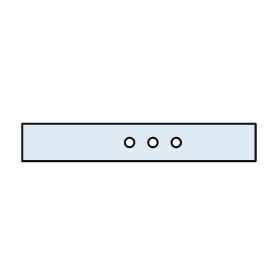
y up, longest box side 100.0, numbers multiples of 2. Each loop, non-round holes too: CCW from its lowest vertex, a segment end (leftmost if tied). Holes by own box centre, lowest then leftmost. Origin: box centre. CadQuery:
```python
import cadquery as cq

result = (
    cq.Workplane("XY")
    .moveTo(-50.0, -8.0)
    .lineTo(50.0, -8.0)
    .lineTo(50.0, 8.0)
    .lineTo(-50.0, 8.0)
    .close()
    .moveTo(-4.0, 0.0)
    .circle(2.0)
    .moveTo(6.0, 0.0)
    .circle(2.0)
    .moveTo(16.0, 0.0)
    .circle(2.0)
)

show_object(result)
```